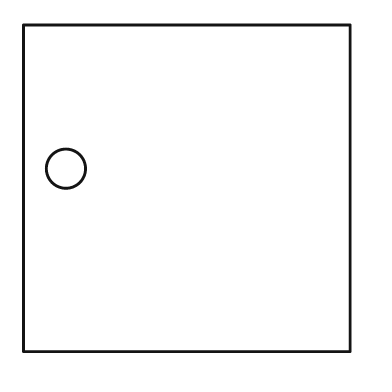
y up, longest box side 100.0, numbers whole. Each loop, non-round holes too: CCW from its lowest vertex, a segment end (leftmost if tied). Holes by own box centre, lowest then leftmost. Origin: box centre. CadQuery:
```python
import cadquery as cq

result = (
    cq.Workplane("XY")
    .moveTo(-50.0, -50.0)
    .lineTo(50.0, -50.0)
    .lineTo(50.0, 50.0)
    .lineTo(-50.0, 50.0)
    .close()
    .moveTo(-37.0, 6.0)
    .circle(6.0)
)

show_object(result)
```